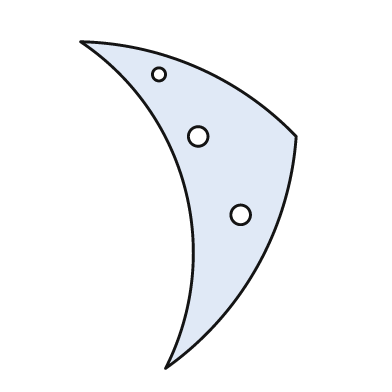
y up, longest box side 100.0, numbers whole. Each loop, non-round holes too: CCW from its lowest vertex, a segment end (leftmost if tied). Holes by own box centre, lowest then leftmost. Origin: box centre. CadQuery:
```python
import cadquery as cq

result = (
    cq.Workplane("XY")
    .moveTo(-7.0, -50.0)
    .threePointArc((21.0, -19.0), (33.0, 21.0))
    .threePointArc((3.0, 42.0), (-33.0, 50.0))
    .threePointArc((-1.0, 5.0), (-7.0, -50.0))
    .close()
    .moveTo(16.0, -3.0)
    .circle(3.0)
    .moveTo(3.0, 21.0)
    .circle(3.0)
    .moveTo(-9.0, 40.0)
    .circle(2.0)
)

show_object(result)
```